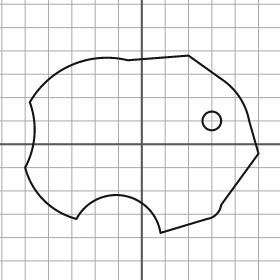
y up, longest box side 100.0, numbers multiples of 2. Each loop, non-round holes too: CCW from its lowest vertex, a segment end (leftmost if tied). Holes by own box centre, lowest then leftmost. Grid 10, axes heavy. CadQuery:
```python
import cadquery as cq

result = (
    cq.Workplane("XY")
    .moveTo(8.0, -38.0)
    .lineTo(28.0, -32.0)
    .threePointArc((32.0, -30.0), (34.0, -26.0))
    .lineTo(50.0, -4.0)
    .lineTo(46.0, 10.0)
    .threePointArc((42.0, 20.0), (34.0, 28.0))
    .lineTo(20.0, 38.0)
    .lineTo(-6.0, 36.0)
    .threePointArc((-30.0, 34.0), (-48.0, 18.0))
    .threePointArc((-46.0, 4.0), (-50.0, -10.0))
    .threePointArc((-42.0, -24.0), (-28.0, -32.0))
    .threePointArc((-8.0, -22.0), (8.0, -38.0))
    .close()
    .moveTo(30.0, 10.0)
    .circle(4.0)
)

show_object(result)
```